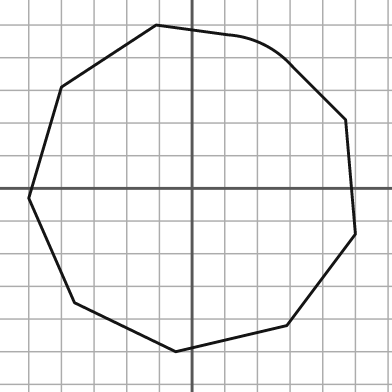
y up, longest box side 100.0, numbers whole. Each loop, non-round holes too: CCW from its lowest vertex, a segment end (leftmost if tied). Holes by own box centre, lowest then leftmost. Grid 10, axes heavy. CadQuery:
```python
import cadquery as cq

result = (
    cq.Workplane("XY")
    .moveTo(-5.0, -50.0)
    .lineTo(29.0, -42.0)
    .lineTo(50.0, -14.0)
    .lineTo(47.0, 21.0)
    .lineTo(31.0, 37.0)
    .threePointArc((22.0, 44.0), (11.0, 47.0))
    .lineTo(-11.0, 50.0)
    .lineTo(-40.0, 31.0)
    .lineTo(-50.0, -3.0)
    .lineTo(-36.0, -35.0)
    .close()
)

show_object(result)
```